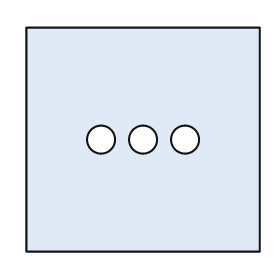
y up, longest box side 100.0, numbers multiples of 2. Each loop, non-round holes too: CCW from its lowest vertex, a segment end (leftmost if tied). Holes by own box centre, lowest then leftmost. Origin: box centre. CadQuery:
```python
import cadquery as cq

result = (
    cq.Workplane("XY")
    .moveTo(-50.0, -48.0)
    .lineTo(50.0, -48.0)
    .lineTo(50.0, 48.0)
    .lineTo(-50.0, 48.0)
    .close()
    .moveTo(-18.0, 0.0)
    .circle(6.0)
    .moveTo(0.0, 0.0)
    .circle(6.0)
    .moveTo(18.0, 0.0)
    .circle(6.0)
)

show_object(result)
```